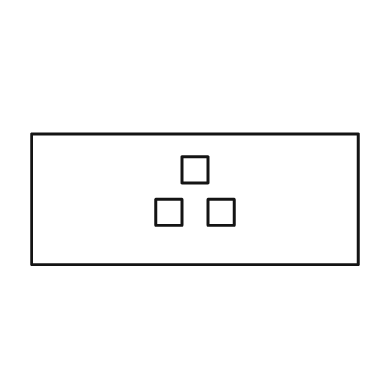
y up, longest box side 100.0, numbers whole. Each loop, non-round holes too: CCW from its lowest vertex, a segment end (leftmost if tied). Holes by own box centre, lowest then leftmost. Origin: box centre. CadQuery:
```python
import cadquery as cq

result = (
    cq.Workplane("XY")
    .moveTo(-50.0, -20.0)
    .lineTo(50.0, -20.0)
    .lineTo(50.0, 20.0)
    .lineTo(-50.0, 20.0)
    .close()
    .moveTo(-12.0, -8.0)
    .lineTo(-4.0, -8.0)
    .lineTo(-4.0, 0.0)
    .lineTo(-12.0, 0.0)
    .close()
    .moveTo(4.0, -8.0)
    .lineTo(12.0, -8.0)
    .lineTo(12.0, 0.0)
    .lineTo(4.0, 0.0)
    .close()
    .moveTo(-4.0, 5.0)
    .lineTo(4.0, 5.0)
    .lineTo(4.0, 13.0)
    .lineTo(-4.0, 13.0)
    .close()
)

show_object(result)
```